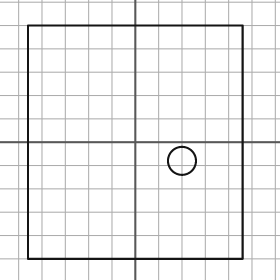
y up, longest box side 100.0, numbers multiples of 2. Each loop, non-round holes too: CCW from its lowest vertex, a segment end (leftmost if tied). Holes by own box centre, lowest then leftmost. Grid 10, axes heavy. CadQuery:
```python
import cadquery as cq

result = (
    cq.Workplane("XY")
    .moveTo(-46.0, -50.0)
    .lineTo(46.0, -50.0)
    .lineTo(46.0, 50.0)
    .lineTo(-46.0, 50.0)
    .close()
    .moveTo(20.0, -8.0)
    .circle(6.0)
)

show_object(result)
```